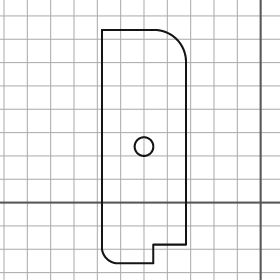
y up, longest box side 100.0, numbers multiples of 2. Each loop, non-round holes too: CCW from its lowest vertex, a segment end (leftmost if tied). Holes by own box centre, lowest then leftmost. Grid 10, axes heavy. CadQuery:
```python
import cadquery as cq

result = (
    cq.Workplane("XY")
    .moveTo(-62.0, -26.0)
    .lineTo(-46.0, -26.0)
    .lineTo(-46.0, -18.0)
    .lineTo(-32.0, -18.0)
    .lineTo(-32.0, 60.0)
    .threePointArc((-36.0, 70.0), (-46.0, 74.0))
    .lineTo(-68.0, 74.0)
    .lineTo(-68.0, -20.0)
    .threePointArc((-66.0, -24.0), (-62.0, -26.0))
    .close()
    .moveTo(-50.0, 24.0)
    .circle(4.0)
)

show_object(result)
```